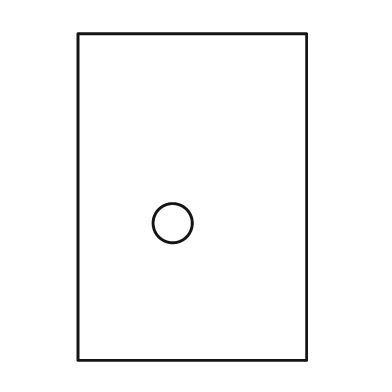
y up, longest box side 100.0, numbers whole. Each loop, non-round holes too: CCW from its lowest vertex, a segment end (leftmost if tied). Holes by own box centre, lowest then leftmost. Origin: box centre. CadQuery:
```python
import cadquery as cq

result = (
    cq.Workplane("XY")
    .moveTo(-35.0, -50.0)
    .lineTo(35.0, -50.0)
    .lineTo(35.0, 50.0)
    .lineTo(-35.0, 50.0)
    .close()
    .moveTo(-6.0, -8.0)
    .circle(6.0)
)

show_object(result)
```